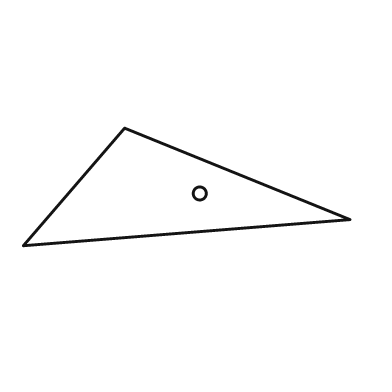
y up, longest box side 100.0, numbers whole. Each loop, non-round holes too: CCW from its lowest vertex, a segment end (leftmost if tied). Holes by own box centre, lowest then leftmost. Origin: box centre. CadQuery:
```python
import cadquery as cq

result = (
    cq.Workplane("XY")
    .moveTo(-50.0, -18.0)
    .lineTo(50.0, -10.0)
    .lineTo(-19.0, 18.0)
    .close()
    .moveTo(4.0, -2.0)
    .circle(2.0)
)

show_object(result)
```